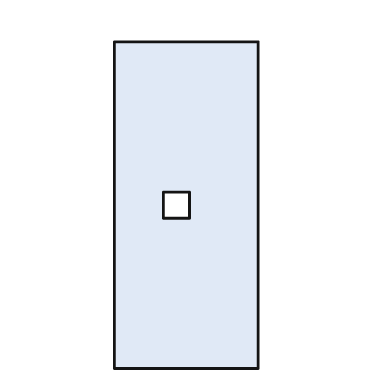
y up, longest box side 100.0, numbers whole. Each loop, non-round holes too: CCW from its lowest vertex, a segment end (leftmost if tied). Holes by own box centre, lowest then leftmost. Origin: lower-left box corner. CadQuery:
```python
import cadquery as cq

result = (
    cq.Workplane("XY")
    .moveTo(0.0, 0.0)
    .lineTo(44.0, 0.0)
    .lineTo(44.0, 100.0)
    .lineTo(0.0, 100.0)
    .close()
    .moveTo(15.0, 46.0)
    .lineTo(23.0, 46.0)
    .lineTo(23.0, 54.0)
    .lineTo(15.0, 54.0)
    .close()
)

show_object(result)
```